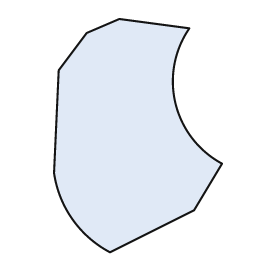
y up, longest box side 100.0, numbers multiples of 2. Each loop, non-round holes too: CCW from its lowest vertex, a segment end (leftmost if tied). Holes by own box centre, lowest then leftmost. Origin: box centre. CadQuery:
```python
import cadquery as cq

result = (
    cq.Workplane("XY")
    .moveTo(-12.0, -50.0)
    .lineTo(24.0, -32.0)
    .lineTo(36.0, -12.0)
    .threePointArc((16.0, 14.0), (22.0, 46.0))
    .lineTo(-8.0, 50.0)
    .lineTo(-22.0, 44.0)
    .lineTo(-34.0, 28.0)
    .lineTo(-36.0, -16.0)
    .threePointArc((-28.0, -36.0), (-12.0, -50.0))
    .close()
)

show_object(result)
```